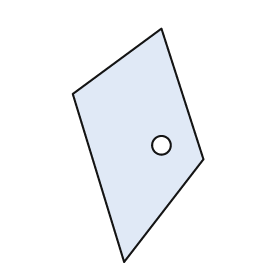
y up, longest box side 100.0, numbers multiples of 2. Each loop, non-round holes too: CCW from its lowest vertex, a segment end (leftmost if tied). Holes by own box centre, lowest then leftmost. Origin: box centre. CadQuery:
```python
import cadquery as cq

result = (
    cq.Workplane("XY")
    .moveTo(-6.0, -50.0)
    .lineTo(28.0, -6.0)
    .lineTo(10.0, 50.0)
    .lineTo(-28.0, 22.0)
    .close()
    .moveTo(10.0, 0.0)
    .circle(4.0)
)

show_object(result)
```